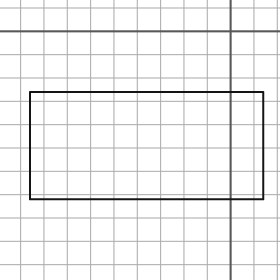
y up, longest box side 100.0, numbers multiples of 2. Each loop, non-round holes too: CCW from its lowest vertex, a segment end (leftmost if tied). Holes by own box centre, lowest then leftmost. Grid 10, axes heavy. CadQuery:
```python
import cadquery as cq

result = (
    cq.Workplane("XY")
    .moveTo(-86.0, -72.0)
    .lineTo(14.0, -72.0)
    .lineTo(14.0, -26.0)
    .lineTo(-86.0, -26.0)
    .close()
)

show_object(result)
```